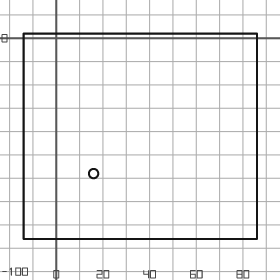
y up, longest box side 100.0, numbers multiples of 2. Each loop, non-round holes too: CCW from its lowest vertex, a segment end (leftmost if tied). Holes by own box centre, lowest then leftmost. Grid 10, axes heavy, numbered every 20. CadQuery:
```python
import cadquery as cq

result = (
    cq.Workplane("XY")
    .moveTo(-14.0, -86.0)
    .lineTo(86.0, -86.0)
    .lineTo(86.0, 2.0)
    .lineTo(-14.0, 2.0)
    .close()
    .moveTo(16.0, -58.0)
    .circle(2.0)
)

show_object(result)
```